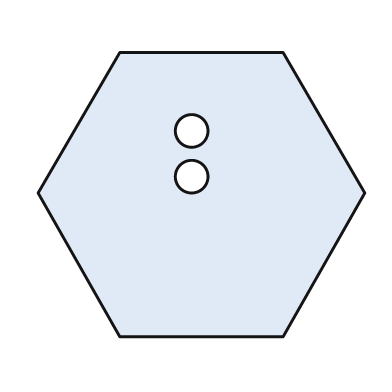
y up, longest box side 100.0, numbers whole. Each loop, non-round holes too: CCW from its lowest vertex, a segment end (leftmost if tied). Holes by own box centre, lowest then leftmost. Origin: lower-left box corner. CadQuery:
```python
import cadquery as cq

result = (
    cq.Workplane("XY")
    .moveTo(25.0, 0.0)
    .lineTo(75.0, 0.0)
    .lineTo(100.0, 44.0)
    .lineTo(75.0, 87.0)
    .lineTo(25.0, 87.0)
    .lineTo(0.0, 44.0)
    .close()
    .moveTo(47.0, 49.0)
    .circle(5.0)
    .moveTo(47.0, 63.0)
    .circle(5.0)
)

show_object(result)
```